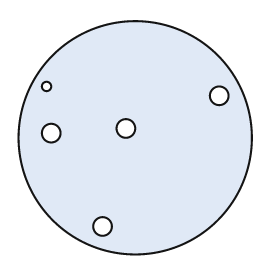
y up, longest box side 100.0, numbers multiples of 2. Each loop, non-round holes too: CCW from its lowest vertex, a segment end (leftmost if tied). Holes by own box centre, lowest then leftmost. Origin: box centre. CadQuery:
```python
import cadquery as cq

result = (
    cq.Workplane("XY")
    .moveTo(0.0, 0.0)
    .circle(50.0)
    .moveTo(-14.0, -38.0)
    .circle(4.0)
    .moveTo(-36.0, 2.0)
    .circle(4.0)
    .moveTo(-4.0, 4.0)
    .circle(4.0)
    .moveTo(36.0, 18.0)
    .circle(4.0)
    .moveTo(-38.0, 22.0)
    .circle(2.0)
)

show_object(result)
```